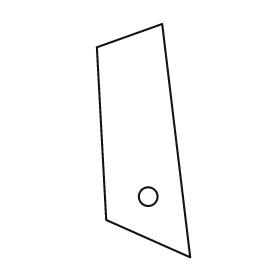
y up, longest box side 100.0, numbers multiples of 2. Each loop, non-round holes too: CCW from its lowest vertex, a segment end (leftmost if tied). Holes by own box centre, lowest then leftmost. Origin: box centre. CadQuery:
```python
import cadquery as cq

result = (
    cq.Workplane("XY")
    .moveTo(20.0, -50.0)
    .lineTo(8.0, 50.0)
    .lineTo(-20.0, 40.0)
    .lineTo(-16.0, -34.0)
    .close()
    .moveTo(2.0, -24.0)
    .circle(4.0)
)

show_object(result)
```